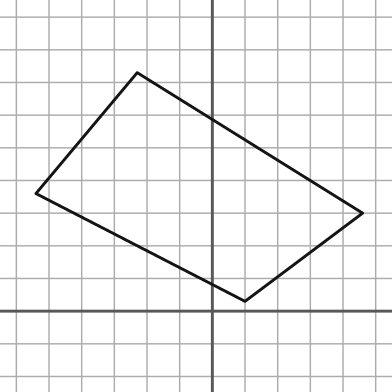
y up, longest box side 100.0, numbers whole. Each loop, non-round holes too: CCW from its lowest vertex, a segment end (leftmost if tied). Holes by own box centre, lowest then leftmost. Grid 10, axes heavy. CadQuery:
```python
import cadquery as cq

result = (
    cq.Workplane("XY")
    .moveTo(10.0, 3.0)
    .lineTo(46.0, 30.0)
    .lineTo(-23.0, 73.0)
    .lineTo(-54.0, 36.0)
    .close()
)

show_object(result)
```